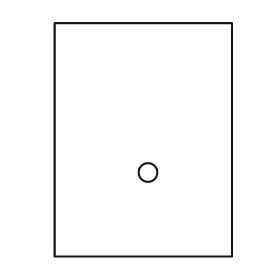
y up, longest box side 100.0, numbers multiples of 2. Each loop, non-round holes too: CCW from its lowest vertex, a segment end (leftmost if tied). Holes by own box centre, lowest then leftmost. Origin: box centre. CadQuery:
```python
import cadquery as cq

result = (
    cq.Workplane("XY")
    .moveTo(-38.0, -50.0)
    .lineTo(38.0, -50.0)
    .lineTo(38.0, 50.0)
    .lineTo(-38.0, 50.0)
    .close()
    .moveTo(2.0, -14.0)
    .circle(4.0)
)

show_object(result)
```